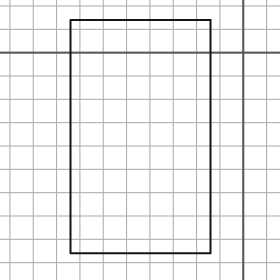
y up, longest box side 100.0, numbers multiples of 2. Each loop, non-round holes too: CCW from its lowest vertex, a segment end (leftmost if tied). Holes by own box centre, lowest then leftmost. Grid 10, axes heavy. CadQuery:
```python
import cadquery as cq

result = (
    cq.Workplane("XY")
    .moveTo(-74.0, -86.0)
    .lineTo(-14.0, -86.0)
    .lineTo(-14.0, 14.0)
    .lineTo(-74.0, 14.0)
    .close()
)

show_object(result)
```